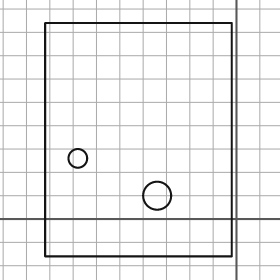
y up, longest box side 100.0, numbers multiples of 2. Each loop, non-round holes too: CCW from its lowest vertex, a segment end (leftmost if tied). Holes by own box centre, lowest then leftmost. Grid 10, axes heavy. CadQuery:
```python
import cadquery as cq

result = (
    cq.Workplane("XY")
    .moveTo(-82.0, -16.0)
    .lineTo(-2.0, -16.0)
    .lineTo(-2.0, 84.0)
    .lineTo(-82.0, 84.0)
    .close()
    .moveTo(-34.0, 10.0)
    .circle(6.0)
    .moveTo(-68.0, 26.0)
    .circle(4.0)
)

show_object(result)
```